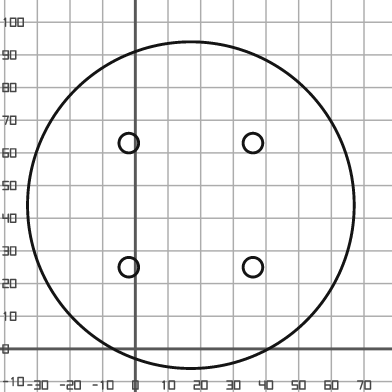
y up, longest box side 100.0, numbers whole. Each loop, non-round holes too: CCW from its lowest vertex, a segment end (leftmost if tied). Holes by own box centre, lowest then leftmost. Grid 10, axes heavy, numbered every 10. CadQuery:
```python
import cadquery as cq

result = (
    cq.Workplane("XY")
    .moveTo(17.0, 44.0)
    .circle(50.0)
    .moveTo(-2.0, 25.0)
    .circle(3.0)
    .moveTo(36.0, 25.0)
    .circle(3.0)
    .moveTo(-2.0, 63.0)
    .circle(3.0)
    .moveTo(36.0, 63.0)
    .circle(3.0)
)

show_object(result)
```